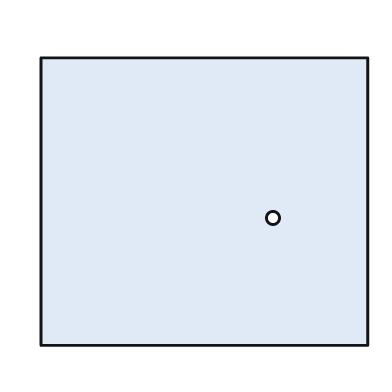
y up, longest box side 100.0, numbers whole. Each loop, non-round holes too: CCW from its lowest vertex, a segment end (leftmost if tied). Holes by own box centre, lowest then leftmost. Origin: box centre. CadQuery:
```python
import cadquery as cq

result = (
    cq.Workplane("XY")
    .moveTo(-50.0, -44.0)
    .lineTo(50.0, -44.0)
    .lineTo(50.0, 44.0)
    .lineTo(-50.0, 44.0)
    .close()
    .moveTo(21.0, -5.0)
    .circle(2.0)
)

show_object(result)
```